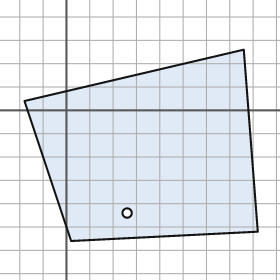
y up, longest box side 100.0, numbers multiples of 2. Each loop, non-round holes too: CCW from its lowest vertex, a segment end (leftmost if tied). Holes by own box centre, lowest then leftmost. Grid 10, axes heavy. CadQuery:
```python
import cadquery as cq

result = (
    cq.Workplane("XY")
    .moveTo(2.0, -56.0)
    .lineTo(82.0, -52.0)
    .lineTo(76.0, 26.0)
    .lineTo(-18.0, 4.0)
    .close()
    .moveTo(26.0, -44.0)
    .circle(2.0)
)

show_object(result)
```